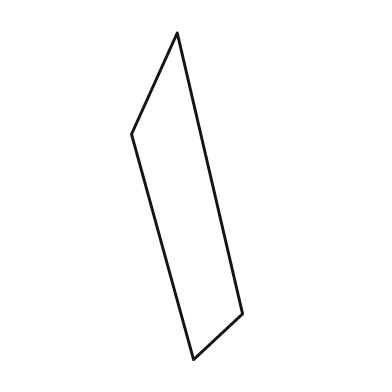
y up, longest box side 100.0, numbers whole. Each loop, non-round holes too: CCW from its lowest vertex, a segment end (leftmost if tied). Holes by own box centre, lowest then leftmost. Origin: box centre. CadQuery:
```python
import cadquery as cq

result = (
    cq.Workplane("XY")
    .moveTo(2.0, -50.0)
    .lineTo(17.0, -36.0)
    .lineTo(-3.0, 50.0)
    .lineTo(-17.0, 19.0)
    .close()
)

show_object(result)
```